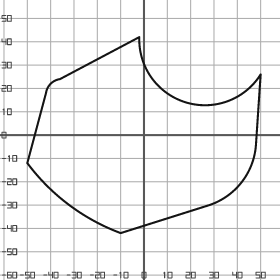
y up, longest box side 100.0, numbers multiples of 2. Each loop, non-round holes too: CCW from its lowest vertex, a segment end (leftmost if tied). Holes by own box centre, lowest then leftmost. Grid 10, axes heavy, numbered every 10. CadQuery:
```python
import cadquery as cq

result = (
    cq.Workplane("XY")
    .moveTo(-10.0, -42.0)
    .lineTo(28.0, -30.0)
    .threePointArc((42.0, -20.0), (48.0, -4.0))
    .lineTo(50.0, 26.0)
    .threePointArc((18.0, 14.0), (-2.0, 42.0))
    .lineTo(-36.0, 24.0)
    .threePointArc((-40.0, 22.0), (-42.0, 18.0))
    .lineTo(-50.0, -12.0)
    .threePointArc((-32.0, -30.0), (-10.0, -42.0))
    .close()
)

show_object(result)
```